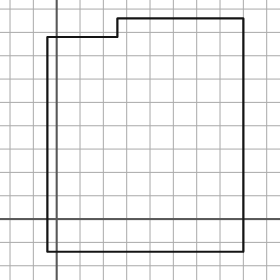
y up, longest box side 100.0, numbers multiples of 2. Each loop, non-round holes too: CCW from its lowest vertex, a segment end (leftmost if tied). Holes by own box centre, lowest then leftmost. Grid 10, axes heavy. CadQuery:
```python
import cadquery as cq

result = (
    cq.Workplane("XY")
    .moveTo(-4.0, -14.0)
    .lineTo(80.0, -14.0)
    .lineTo(80.0, 86.0)
    .lineTo(26.0, 86.0)
    .lineTo(26.0, 78.0)
    .lineTo(-4.0, 78.0)
    .close()
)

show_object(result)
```